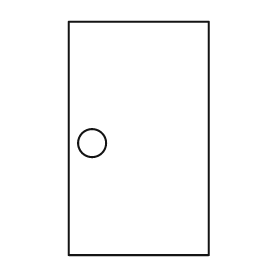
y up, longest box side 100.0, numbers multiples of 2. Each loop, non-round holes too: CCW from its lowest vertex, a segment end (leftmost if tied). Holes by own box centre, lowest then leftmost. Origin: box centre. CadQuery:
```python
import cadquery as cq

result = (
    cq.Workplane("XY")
    .moveTo(-30.0, -50.0)
    .lineTo(30.0, -50.0)
    .lineTo(30.0, 50.0)
    .lineTo(-30.0, 50.0)
    .close()
    .moveTo(-20.0, -2.0)
    .circle(6.0)
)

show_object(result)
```